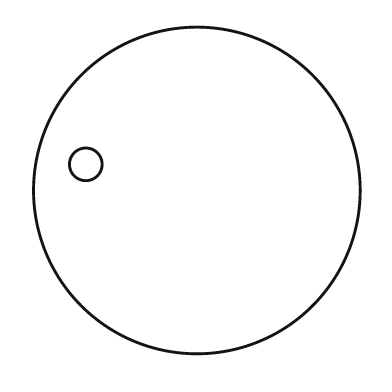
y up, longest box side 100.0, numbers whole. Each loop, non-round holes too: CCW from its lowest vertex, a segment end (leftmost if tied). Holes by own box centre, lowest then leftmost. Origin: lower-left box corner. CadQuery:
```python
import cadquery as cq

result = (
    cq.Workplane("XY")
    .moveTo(50.0, 50.0)
    .circle(50.0)
    .moveTo(16.0, 58.0)
    .circle(5.0)
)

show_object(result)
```